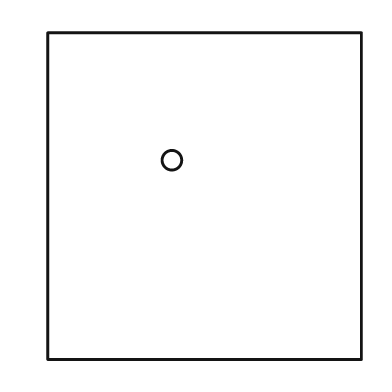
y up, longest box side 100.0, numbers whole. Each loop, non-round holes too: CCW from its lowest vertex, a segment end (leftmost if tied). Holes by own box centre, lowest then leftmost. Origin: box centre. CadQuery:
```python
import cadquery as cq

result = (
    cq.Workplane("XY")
    .moveTo(-48.0, -50.0)
    .lineTo(48.0, -50.0)
    .lineTo(48.0, 50.0)
    .lineTo(-48.0, 50.0)
    .close()
    .moveTo(-10.0, 11.0)
    .circle(3.0)
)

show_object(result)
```